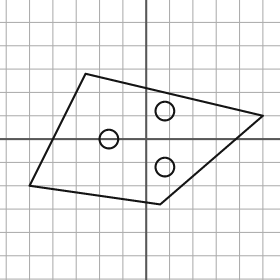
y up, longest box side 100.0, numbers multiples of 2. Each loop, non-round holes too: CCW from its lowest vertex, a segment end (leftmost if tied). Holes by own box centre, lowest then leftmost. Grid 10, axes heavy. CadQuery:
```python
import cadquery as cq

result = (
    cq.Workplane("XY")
    .moveTo(6.0, -28.0)
    .lineTo(50.0, 10.0)
    .lineTo(-26.0, 28.0)
    .lineTo(-50.0, -20.0)
    .close()
    .moveTo(8.0, -12.0)
    .circle(4.0)
    .moveTo(-16.0, 0.0)
    .circle(4.0)
    .moveTo(8.0, 12.0)
    .circle(4.0)
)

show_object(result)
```